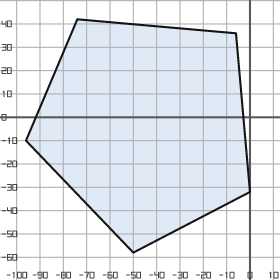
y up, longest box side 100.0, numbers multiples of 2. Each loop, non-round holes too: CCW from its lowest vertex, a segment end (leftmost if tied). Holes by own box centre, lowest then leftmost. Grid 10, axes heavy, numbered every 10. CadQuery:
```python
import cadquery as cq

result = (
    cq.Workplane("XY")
    .moveTo(-50.0, -58.0)
    .lineTo(0.0, -32.0)
    .lineTo(-6.0, 36.0)
    .lineTo(-74.0, 42.0)
    .lineTo(-96.0, -10.0)
    .close()
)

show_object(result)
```